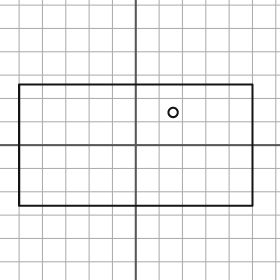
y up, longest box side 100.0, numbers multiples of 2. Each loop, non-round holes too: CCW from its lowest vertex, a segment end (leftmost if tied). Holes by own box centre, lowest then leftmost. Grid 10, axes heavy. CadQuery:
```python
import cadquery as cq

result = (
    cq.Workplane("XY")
    .moveTo(-50.0, -26.0)
    .lineTo(50.0, -26.0)
    .lineTo(50.0, 26.0)
    .lineTo(-50.0, 26.0)
    .close()
    .moveTo(16.0, 14.0)
    .circle(2.0)
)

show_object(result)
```